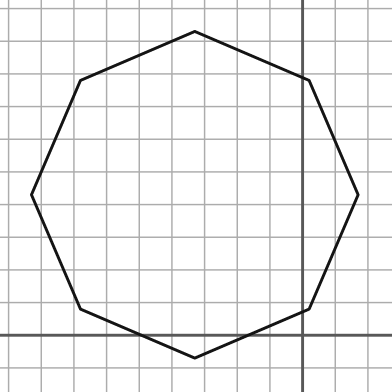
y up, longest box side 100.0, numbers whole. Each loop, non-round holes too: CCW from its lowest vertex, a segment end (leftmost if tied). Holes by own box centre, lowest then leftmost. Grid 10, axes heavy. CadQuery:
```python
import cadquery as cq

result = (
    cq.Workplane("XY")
    .moveTo(-33.0, -7.0)
    .lineTo(2.0, 8.0)
    .lineTo(17.0, 43.0)
    .lineTo(2.0, 78.0)
    .lineTo(-33.0, 93.0)
    .lineTo(-68.0, 78.0)
    .lineTo(-83.0, 43.0)
    .lineTo(-68.0, 8.0)
    .close()
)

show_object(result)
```